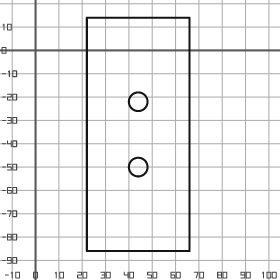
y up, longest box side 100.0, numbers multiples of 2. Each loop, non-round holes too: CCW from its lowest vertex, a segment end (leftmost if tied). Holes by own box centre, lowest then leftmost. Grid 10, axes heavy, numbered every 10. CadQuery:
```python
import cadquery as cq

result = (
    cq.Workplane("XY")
    .moveTo(22.0, -86.0)
    .lineTo(66.0, -86.0)
    .lineTo(66.0, 14.0)
    .lineTo(22.0, 14.0)
    .close()
    .moveTo(44.0, -50.0)
    .circle(4.0)
    .moveTo(44.0, -22.0)
    .circle(4.0)
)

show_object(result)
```